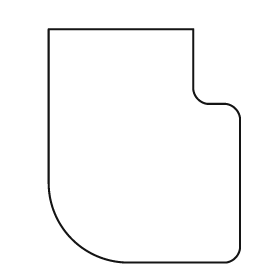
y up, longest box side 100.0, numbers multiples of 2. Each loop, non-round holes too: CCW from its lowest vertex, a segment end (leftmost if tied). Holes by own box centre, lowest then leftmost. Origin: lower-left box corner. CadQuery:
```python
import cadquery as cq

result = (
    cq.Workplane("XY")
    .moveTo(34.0, 0.0)
    .lineTo(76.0, 0.0)
    .threePointArc((80.0, 2.0), (82.0, 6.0))
    .lineTo(82.0, 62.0)
    .threePointArc((80.0, 66.0), (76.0, 68.0))
    .lineTo(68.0, 68.0)
    .threePointArc((64.0, 70.0), (62.0, 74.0))
    .lineTo(62.0, 100.0)
    .lineTo(0.0, 100.0)
    .lineTo(0.0, 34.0)
    .threePointArc((10.0, 10.0), (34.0, 0.0))
    .close()
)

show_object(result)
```